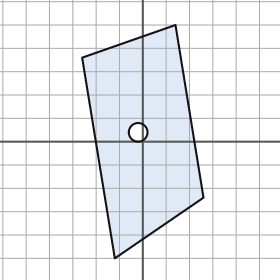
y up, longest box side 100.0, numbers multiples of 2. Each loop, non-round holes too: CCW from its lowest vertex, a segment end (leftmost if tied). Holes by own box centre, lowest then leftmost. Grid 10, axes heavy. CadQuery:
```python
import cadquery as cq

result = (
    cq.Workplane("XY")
    .moveTo(-12.0, -50.0)
    .lineTo(26.0, -24.0)
    .lineTo(14.0, 50.0)
    .lineTo(-26.0, 36.0)
    .close()
    .moveTo(-2.0, 4.0)
    .circle(4.0)
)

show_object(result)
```